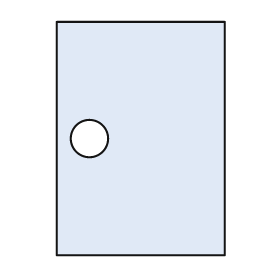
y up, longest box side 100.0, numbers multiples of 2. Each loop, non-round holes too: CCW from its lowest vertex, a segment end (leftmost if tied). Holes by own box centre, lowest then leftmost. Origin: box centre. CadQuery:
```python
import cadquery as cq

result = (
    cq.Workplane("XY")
    .moveTo(-36.0, -50.0)
    .lineTo(36.0, -50.0)
    .lineTo(36.0, 50.0)
    .lineTo(-36.0, 50.0)
    .close()
    .moveTo(-22.0, 0.0)
    .circle(8.0)
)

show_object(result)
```